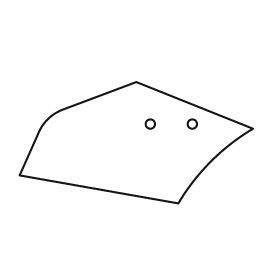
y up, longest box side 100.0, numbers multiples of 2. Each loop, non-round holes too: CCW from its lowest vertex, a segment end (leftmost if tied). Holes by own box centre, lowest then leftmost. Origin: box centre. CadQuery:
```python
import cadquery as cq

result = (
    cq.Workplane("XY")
    .moveTo(18.0, -26.0)
    .threePointArc((32.0, -8.0), (50.0, 6.0))
    .lineTo(0.0, 26.0)
    .lineTo(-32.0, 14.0)
    .threePointArc((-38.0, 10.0), (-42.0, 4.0))
    .lineTo(-50.0, -14.0)
    .close()
    .moveTo(6.0, 8.0)
    .circle(2.0)
    .moveTo(24.0, 8.0)
    .circle(2.0)
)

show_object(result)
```